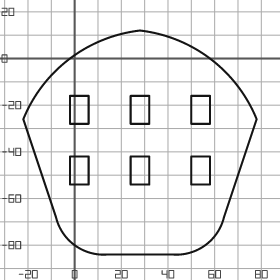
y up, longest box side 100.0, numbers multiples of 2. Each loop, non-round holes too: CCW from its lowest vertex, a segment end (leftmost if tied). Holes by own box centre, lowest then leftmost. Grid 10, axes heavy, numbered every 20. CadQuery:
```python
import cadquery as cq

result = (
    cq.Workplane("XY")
    .moveTo(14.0, -84.0)
    .lineTo(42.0, -84.0)
    .threePointArc((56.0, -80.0), (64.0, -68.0))
    .lineTo(78.0, -26.0)
    .threePointArc((58.0, 0.0), (28.0, 12.0))
    .threePointArc((-2.0, 0.0), (-22.0, -26.0))
    .lineTo(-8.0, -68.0)
    .threePointArc((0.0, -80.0), (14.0, -84.0))
    .close()
    .moveTo(-2.0, -54.0)
    .lineTo(6.0, -54.0)
    .lineTo(6.0, -42.0)
    .lineTo(-2.0, -42.0)
    .close()
    .moveTo(24.0, -54.0)
    .lineTo(32.0, -54.0)
    .lineTo(32.0, -42.0)
    .lineTo(24.0, -42.0)
    .close()
    .moveTo(50.0, -54.0)
    .lineTo(58.0, -54.0)
    .lineTo(58.0, -42.0)
    .lineTo(50.0, -42.0)
    .close()
    .moveTo(-2.0, -28.0)
    .lineTo(6.0, -28.0)
    .lineTo(6.0, -16.0)
    .lineTo(-2.0, -16.0)
    .close()
    .moveTo(24.0, -28.0)
    .lineTo(32.0, -28.0)
    .lineTo(32.0, -16.0)
    .lineTo(24.0, -16.0)
    .close()
    .moveTo(50.0, -28.0)
    .lineTo(58.0, -28.0)
    .lineTo(58.0, -16.0)
    .lineTo(50.0, -16.0)
    .close()
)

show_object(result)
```